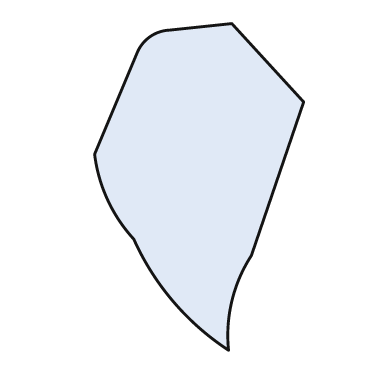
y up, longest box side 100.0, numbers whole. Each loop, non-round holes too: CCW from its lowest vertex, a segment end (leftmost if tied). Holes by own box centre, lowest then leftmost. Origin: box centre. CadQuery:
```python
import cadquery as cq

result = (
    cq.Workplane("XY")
    .moveTo(9.0, -50.0)
    .threePointArc((10.0, -35.0), (16.0, -21.0))
    .lineTo(32.0, 26.0)
    .lineTo(10.0, 50.0)
    .lineTo(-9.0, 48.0)
    .threePointArc((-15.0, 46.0), (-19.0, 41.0))
    .lineTo(-32.0, 10.0)
    .threePointArc((-28.0, -4.0), (-20.0, -16.0))
    .threePointArc((-8.0, -35.0), (9.0, -50.0))
    .close()
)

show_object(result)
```